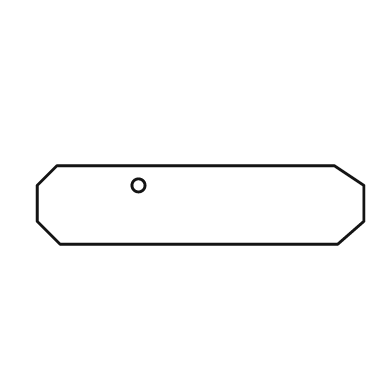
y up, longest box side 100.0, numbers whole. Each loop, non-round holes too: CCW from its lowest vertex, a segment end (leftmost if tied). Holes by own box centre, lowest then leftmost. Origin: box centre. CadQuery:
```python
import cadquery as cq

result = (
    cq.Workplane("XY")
    .moveTo(-43.0, -12.0)
    .lineTo(42.0, -12.0)
    .lineTo(50.0, -5.0)
    .lineTo(50.0, 6.0)
    .lineTo(41.0, 12.0)
    .lineTo(-44.0, 12.0)
    .lineTo(-50.0, 6.0)
    .lineTo(-50.0, -5.0)
    .close()
    .moveTo(-19.0, 6.0)
    .circle(2.0)
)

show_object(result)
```